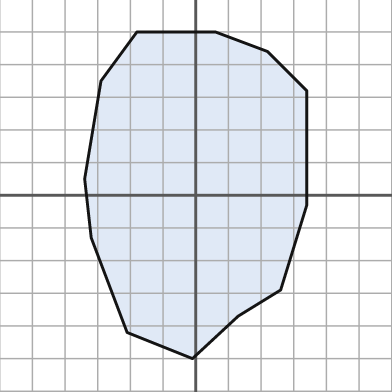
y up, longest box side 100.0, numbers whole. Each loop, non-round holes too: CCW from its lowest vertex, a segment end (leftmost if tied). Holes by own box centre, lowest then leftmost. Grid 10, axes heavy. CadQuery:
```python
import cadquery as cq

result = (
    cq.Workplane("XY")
    .moveTo(-1.0, -50.0)
    .lineTo(13.0, -37.0)
    .lineTo(26.0, -29.0)
    .lineTo(34.0, -3.0)
    .lineTo(34.0, 32.0)
    .lineTo(22.0, 44.0)
    .lineTo(6.0, 50.0)
    .lineTo(-18.0, 50.0)
    .lineTo(-29.0, 35.0)
    .lineTo(-34.0, 5.0)
    .lineTo(-32.0, -13.0)
    .lineTo(-21.0, -42.0)
    .close()
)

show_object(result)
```